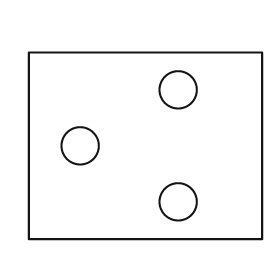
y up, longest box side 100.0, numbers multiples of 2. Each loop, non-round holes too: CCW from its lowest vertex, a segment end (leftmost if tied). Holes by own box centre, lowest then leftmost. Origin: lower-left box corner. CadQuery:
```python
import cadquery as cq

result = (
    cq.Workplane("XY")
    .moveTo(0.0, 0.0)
    .lineTo(100.0, 0.0)
    .lineTo(100.0, 80.0)
    .lineTo(0.0, 80.0)
    .close()
    .moveTo(64.0, 16.0)
    .circle(8.0)
    .moveTo(22.0, 40.0)
    .circle(8.0)
    .moveTo(64.0, 64.0)
    .circle(8.0)
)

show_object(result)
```